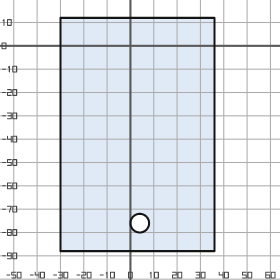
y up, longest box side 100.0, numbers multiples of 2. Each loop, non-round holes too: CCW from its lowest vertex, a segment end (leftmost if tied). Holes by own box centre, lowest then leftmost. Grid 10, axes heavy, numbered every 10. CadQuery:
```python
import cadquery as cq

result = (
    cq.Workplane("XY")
    .moveTo(-30.0, -88.0)
    .lineTo(36.0, -88.0)
    .lineTo(36.0, 12.0)
    .lineTo(-30.0, 12.0)
    .close()
    .moveTo(4.0, -76.0)
    .circle(4.0)
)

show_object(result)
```